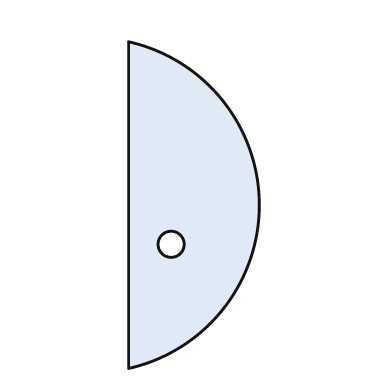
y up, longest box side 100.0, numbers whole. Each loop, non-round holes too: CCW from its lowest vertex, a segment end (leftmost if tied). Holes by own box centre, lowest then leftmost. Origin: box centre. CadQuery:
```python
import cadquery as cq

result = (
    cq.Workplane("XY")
    .moveTo(-20.0, -50.0)
    .threePointArc((20.0, 0.0), (-20.0, 50.0))
    .close()
    .moveTo(-7.0, -12.0)
    .circle(4.0)
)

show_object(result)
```